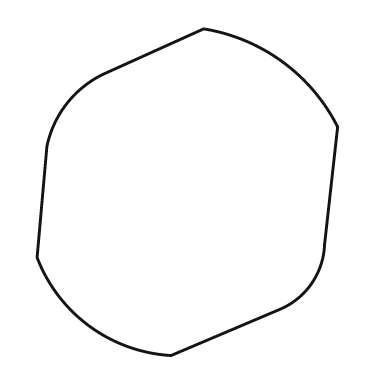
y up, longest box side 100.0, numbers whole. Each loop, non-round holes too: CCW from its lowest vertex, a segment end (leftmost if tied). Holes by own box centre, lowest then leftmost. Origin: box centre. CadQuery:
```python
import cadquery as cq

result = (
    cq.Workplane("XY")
    .moveTo(-5.0, -50.0)
    .lineTo(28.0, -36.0)
    .threePointArc((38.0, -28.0), (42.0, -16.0))
    .lineTo(46.0, 20.0)
    .threePointArc((29.0, 40.0), (5.0, 50.0))
    .lineTo(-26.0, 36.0)
    .threePointArc((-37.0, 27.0), (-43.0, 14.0))
    .lineTo(-46.0, -20.0)
    .threePointArc((-30.0, -41.0), (-5.0, -50.0))
    .close()
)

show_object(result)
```